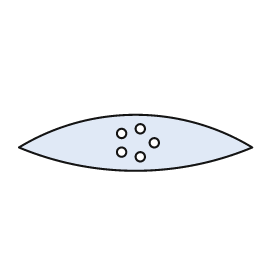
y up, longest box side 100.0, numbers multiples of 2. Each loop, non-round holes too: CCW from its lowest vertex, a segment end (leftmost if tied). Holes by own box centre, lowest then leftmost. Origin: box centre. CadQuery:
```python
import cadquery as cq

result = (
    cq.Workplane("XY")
    .moveTo(-50.0, -2.0)
    .threePointArc((0.0, -12.0), (50.0, -2.0))
    .threePointArc((0.0, 12.0), (-50.0, -2.0))
    .close()
    .moveTo(2.0, -6.0)
    .circle(2.0)
    .moveTo(-6.0, -4.0)
    .circle(2.0)
    .moveTo(8.0, 0.0)
    .circle(2.0)
    .moveTo(-6.0, 4.0)
    .circle(2.0)
    .moveTo(2.0, 6.0)
    .circle(2.0)
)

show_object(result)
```